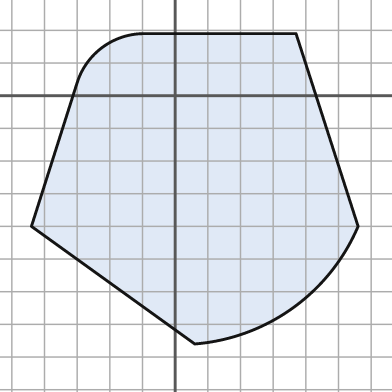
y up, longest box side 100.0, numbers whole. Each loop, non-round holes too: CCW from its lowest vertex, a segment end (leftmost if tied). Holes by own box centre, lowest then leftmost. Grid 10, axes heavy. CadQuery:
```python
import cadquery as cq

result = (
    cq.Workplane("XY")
    .moveTo(6.0, -76.0)
    .threePointArc((36.0, -65.0), (56.0, -40.0))
    .lineTo(37.0, 19.0)
    .lineTo(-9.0, 19.0)
    .threePointArc((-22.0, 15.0), (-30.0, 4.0))
    .lineTo(-44.0, -40.0)
    .close()
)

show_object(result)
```